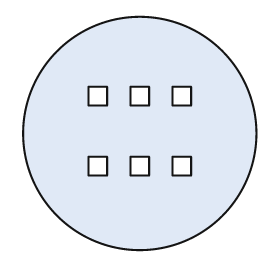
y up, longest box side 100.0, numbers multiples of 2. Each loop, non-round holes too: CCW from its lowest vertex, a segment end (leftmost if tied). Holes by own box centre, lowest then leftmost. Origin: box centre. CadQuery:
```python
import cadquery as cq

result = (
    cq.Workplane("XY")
    .moveTo(0.0, 0.0)
    .circle(50.0)
    .moveTo(-22.0, -18.0)
    .lineTo(-14.0, -18.0)
    .lineTo(-14.0, -10.0)
    .lineTo(-22.0, -10.0)
    .close()
    .moveTo(-4.0, -18.0)
    .lineTo(4.0, -18.0)
    .lineTo(4.0, -10.0)
    .lineTo(-4.0, -10.0)
    .close()
    .moveTo(14.0, -18.0)
    .lineTo(22.0, -18.0)
    .lineTo(22.0, -10.0)
    .lineTo(14.0, -10.0)
    .close()
    .moveTo(-22.0, 12.0)
    .lineTo(-14.0, 12.0)
    .lineTo(-14.0, 20.0)
    .lineTo(-22.0, 20.0)
    .close()
    .moveTo(-4.0, 12.0)
    .lineTo(4.0, 12.0)
    .lineTo(4.0, 20.0)
    .lineTo(-4.0, 20.0)
    .close()
    .moveTo(14.0, 12.0)
    .lineTo(22.0, 12.0)
    .lineTo(22.0, 20.0)
    .lineTo(14.0, 20.0)
    .close()
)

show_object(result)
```